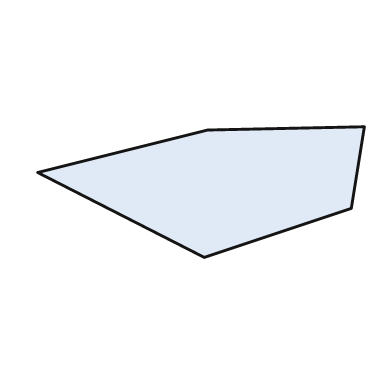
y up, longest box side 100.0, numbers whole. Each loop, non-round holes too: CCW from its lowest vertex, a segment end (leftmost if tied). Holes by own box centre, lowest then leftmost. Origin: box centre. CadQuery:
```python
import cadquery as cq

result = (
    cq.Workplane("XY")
    .moveTo(1.0, -20.0)
    .lineTo(46.0, -5.0)
    .lineTo(50.0, 20.0)
    .lineTo(2.0, 19.0)
    .lineTo(-50.0, 6.0)
    .close()
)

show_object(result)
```